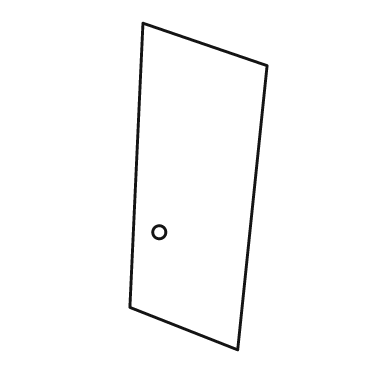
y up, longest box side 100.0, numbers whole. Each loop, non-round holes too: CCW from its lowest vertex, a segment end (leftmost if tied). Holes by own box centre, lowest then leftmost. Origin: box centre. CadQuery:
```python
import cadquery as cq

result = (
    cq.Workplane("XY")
    .moveTo(12.0, -50.0)
    .lineTo(21.0, 37.0)
    .lineTo(-17.0, 50.0)
    .lineTo(-21.0, -37.0)
    .close()
    .moveTo(-12.0, -14.0)
    .circle(2.0)
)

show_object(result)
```